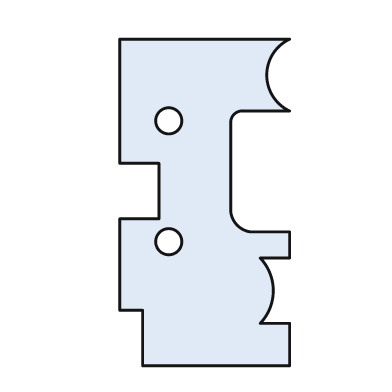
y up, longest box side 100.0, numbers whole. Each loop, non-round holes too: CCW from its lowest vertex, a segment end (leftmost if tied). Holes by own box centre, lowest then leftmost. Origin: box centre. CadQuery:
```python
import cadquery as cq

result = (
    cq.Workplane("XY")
    .moveTo(-19.0, -50.0)
    .lineTo(26.0, -50.0)
    .lineTo(26.0, -37.0)
    .lineTo(17.0, -37.0)
    .threePointArc((21.0, -27.0), (17.0, -17.0))
    .lineTo(26.0, -17.0)
    .lineTo(26.0, -9.0)
    .lineTo(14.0, -9.0)
    .threePointArc((10.0, -7.0), (8.0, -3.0))
    .lineTo(8.0, 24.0)
    .threePointArc((9.0, 27.0), (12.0, 28.0))
    .lineTo(26.0, 28.0)
    .threePointArc((19.0, 39.0), (26.0, 50.0))
    .lineTo(-26.0, 50.0)
    .lineTo(-26.0, 12.0)
    .lineTo(-14.0, 12.0)
    .lineTo(-14.0, -5.0)
    .lineTo(-26.0, -5.0)
    .lineTo(-26.0, -33.0)
    .lineTo(-19.0, -33.0)
    .close()
    .moveTo(-11.0, -12.0)
    .circle(4.0)
    .moveTo(-11.0, 25.0)
    .circle(4.0)
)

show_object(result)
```